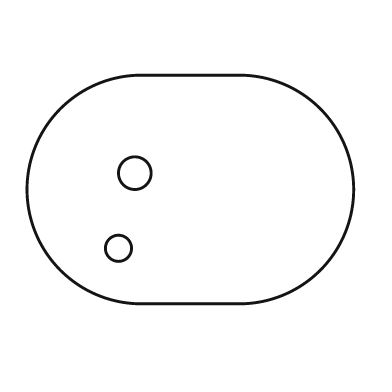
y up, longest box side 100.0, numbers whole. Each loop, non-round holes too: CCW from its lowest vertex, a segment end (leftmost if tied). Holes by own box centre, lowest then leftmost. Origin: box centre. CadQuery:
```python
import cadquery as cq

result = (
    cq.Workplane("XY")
    .moveTo(-15.0, -35.0)
    .lineTo(15.0, -35.0)
    .threePointArc((50.0, 0.0), (15.0, 35.0))
    .lineTo(-15.0, 35.0)
    .threePointArc((-50.0, 0.0), (-15.0, -35.0))
    .close()
    .moveTo(-22.0, -18.0)
    .circle(4.0)
    .moveTo(-17.0, 5.0)
    .circle(5.0)
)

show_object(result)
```